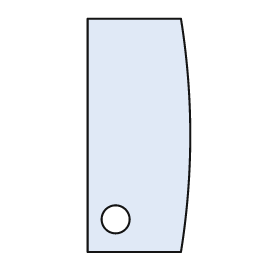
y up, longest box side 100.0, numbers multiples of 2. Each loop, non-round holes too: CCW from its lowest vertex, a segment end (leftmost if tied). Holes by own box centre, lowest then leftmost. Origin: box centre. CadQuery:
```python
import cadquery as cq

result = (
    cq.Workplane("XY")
    .moveTo(-22.0, -50.0)
    .lineTo(18.0, -50.0)
    .threePointArc((22.0, 0.0), (18.0, 50.0))
    .lineTo(-22.0, 50.0)
    .close()
    .moveTo(-10.0, -36.0)
    .circle(6.0)
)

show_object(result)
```